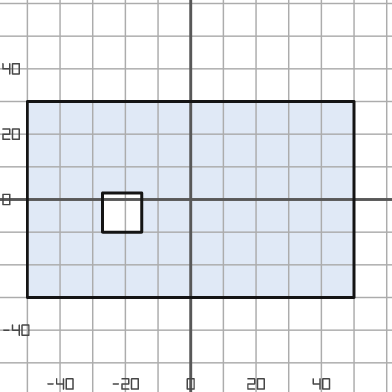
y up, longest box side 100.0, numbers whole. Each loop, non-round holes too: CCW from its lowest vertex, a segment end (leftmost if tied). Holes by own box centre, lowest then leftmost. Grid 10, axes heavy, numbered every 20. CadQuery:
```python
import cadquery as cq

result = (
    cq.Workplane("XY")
    .moveTo(-50.0, -30.0)
    .lineTo(50.0, -30.0)
    .lineTo(50.0, 30.0)
    .lineTo(-50.0, 30.0)
    .close()
    .moveTo(-27.0, -10.0)
    .lineTo(-15.0, -10.0)
    .lineTo(-15.0, 2.0)
    .lineTo(-27.0, 2.0)
    .close()
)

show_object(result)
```